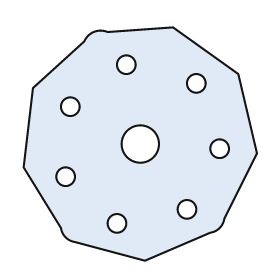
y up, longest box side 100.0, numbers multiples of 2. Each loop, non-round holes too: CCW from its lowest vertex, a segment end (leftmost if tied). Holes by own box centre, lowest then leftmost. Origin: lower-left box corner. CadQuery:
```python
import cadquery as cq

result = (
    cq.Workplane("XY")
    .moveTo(52.0, 0.0)
    .lineTo(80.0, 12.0)
    .threePointArc((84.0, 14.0), (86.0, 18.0))
    .lineTo(100.0, 46.0)
    .lineTo(92.0, 80.0)
    .lineTo(64.0, 100.0)
    .lineTo(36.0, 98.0)
    .threePointArc((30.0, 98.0), (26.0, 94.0))
    .lineTo(4.0, 74.0)
    .lineTo(0.0, 40.0)
    .lineTo(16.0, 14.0)
    .threePointArc((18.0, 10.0), (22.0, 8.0))
    .close()
    .moveTo(40.0, 16.0)
    .circle(4.0)
    .moveTo(70.0, 22.0)
    .circle(4.0)
    .moveTo(18.0, 36.0)
    .circle(4.0)
    .moveTo(84.0, 48.0)
    .circle(4.0)
    .moveTo(50.0, 50.0)
    .circle(8.0)
    .moveTo(20.0, 66.0)
    .circle(4.0)
    .moveTo(74.0, 76.0)
    .circle(4.0)
    .moveTo(44.0, 84.0)
    .circle(4.0)
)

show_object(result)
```